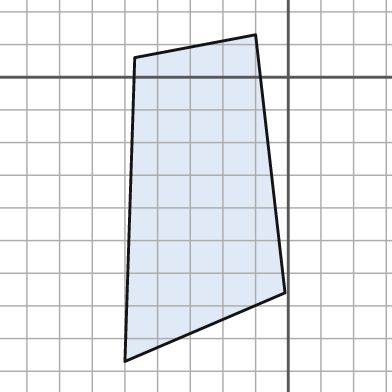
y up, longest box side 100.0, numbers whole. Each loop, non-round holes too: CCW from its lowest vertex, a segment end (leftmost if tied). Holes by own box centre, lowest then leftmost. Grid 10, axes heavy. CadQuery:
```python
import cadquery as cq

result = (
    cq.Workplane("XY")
    .moveTo(-50.0, -87.0)
    .lineTo(-1.0, -66.0)
    .lineTo(-10.0, 13.0)
    .lineTo(-47.0, 6.0)
    .close()
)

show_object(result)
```